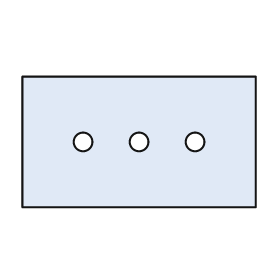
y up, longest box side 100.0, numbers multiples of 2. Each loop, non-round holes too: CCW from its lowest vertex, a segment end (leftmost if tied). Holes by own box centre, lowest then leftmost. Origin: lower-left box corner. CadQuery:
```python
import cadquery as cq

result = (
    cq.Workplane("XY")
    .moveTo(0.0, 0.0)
    .lineTo(100.0, 0.0)
    .lineTo(100.0, 56.0)
    .lineTo(0.0, 56.0)
    .close()
    .moveTo(26.0, 28.0)
    .circle(4.0)
    .moveTo(50.0, 28.0)
    .circle(4.0)
    .moveTo(74.0, 28.0)
    .circle(4.0)
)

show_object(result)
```